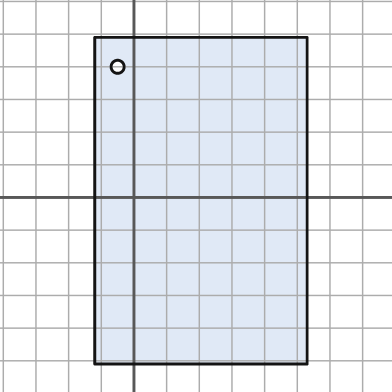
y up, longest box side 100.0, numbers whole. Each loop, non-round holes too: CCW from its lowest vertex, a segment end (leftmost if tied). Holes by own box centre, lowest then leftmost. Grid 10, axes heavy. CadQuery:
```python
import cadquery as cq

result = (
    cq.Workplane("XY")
    .moveTo(-12.0, -51.0)
    .lineTo(53.0, -51.0)
    .lineTo(53.0, 49.0)
    .lineTo(-12.0, 49.0)
    .close()
    .moveTo(-5.0, 40.0)
    .circle(2.0)
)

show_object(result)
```